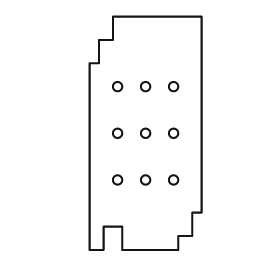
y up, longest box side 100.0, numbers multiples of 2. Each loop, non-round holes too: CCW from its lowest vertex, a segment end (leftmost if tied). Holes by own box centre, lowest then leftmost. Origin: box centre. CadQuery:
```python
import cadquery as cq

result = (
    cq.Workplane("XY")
    .moveTo(-24.0, -50.0)
    .lineTo(-18.0, -50.0)
    .lineTo(-18.0, -40.0)
    .lineTo(-10.0, -40.0)
    .lineTo(-10.0, -50.0)
    .lineTo(14.0, -50.0)
    .lineTo(14.0, -44.0)
    .lineTo(20.0, -44.0)
    .lineTo(20.0, -34.0)
    .lineTo(24.0, -34.0)
    .lineTo(24.0, 50.0)
    .lineTo(-14.0, 50.0)
    .lineTo(-14.0, 40.0)
    .lineTo(-20.0, 40.0)
    .lineTo(-20.0, 30.0)
    .lineTo(-24.0, 30.0)
    .close()
    .moveTo(-12.0, -20.0)
    .circle(2.0)
    .moveTo(0.0, -20.0)
    .circle(2.0)
    .moveTo(12.0, -20.0)
    .circle(2.0)
    .moveTo(-12.0, 0.0)
    .circle(2.0)
    .moveTo(0.0, 0.0)
    .circle(2.0)
    .moveTo(12.0, 0.0)
    .circle(2.0)
    .moveTo(-12.0, 20.0)
    .circle(2.0)
    .moveTo(0.0, 20.0)
    .circle(2.0)
    .moveTo(12.0, 20.0)
    .circle(2.0)
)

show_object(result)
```